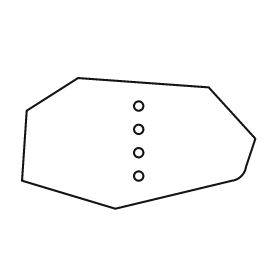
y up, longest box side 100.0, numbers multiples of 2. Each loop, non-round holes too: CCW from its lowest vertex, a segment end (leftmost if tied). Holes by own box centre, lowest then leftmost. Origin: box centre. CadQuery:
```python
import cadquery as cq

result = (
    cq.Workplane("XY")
    .moveTo(-10.0, -28.0)
    .lineTo(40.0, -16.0)
    .threePointArc((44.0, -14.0), (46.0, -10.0))
    .lineTo(50.0, 2.0)
    .lineTo(30.0, 24.0)
    .lineTo(-26.0, 28.0)
    .lineTo(-48.0, 14.0)
    .lineTo(-50.0, -16.0)
    .close()
    .moveTo(0.0, -14.0)
    .circle(2.0)
    .moveTo(0.0, -4.0)
    .circle(2.0)
    .moveTo(0.0, 6.0)
    .circle(2.0)
    .moveTo(0.0, 16.0)
    .circle(2.0)
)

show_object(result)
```